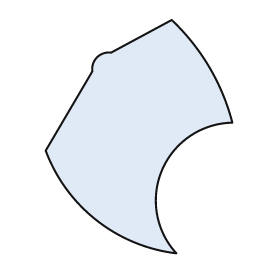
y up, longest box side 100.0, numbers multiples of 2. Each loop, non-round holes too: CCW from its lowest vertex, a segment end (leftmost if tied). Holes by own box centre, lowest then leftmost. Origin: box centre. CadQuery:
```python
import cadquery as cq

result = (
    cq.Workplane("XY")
    .moveTo(16.0, -50.0)
    .threePointArc((10.0, -14.0), (40.0, 6.0))
    .threePointArc((30.0, 30.0), (14.0, 50.0))
    .lineTo(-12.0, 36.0)
    .threePointArc((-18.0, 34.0), (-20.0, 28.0))
    .lineTo(-40.0, -6.0)
    .threePointArc((-18.0, -36.0), (16.0, -50.0))
    .close()
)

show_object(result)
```